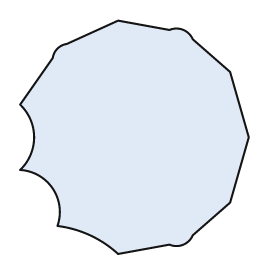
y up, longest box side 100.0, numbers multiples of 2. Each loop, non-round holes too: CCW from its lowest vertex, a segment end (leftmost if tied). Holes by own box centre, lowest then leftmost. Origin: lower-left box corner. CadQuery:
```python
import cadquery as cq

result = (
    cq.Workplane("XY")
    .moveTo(42.0, 0.0)
    .lineTo(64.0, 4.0)
    .threePointArc((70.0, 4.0), (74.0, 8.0))
    .lineTo(90.0, 22.0)
    .lineTo(98.0, 50.0)
    .lineTo(90.0, 78.0)
    .lineTo(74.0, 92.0)
    .threePointArc((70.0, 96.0), (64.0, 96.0))
    .lineTo(42.0, 100.0)
    .lineTo(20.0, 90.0)
    .threePointArc((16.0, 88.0), (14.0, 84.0))
    .lineTo(0.0, 64.0)
    .threePointArc((6.0, 50.0), (0.0, 36.0))
    .threePointArc((14.0, 28.0), (16.0, 12.0))
    .threePointArc((30.0, 8.0), (42.0, 0.0))
    .close()
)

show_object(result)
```